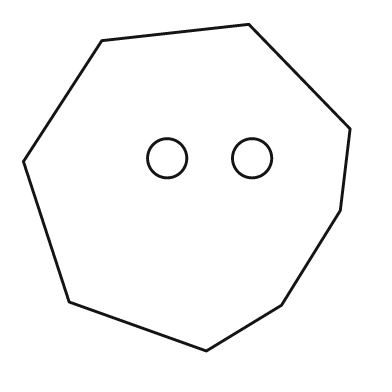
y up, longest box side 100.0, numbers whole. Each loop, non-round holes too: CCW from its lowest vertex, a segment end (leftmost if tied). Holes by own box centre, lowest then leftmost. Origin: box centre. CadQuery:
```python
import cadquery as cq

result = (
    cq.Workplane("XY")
    .moveTo(6.0, -50.0)
    .lineTo(29.0, -36.0)
    .lineTo(47.0, -7.0)
    .lineTo(50.0, 18.0)
    .lineTo(19.0, 50.0)
    .lineTo(-26.0, 45.0)
    .lineTo(-50.0, 8.0)
    .lineTo(-36.0, -35.0)
    .close()
    .moveTo(-6.0, 9.0)
    .circle(6.0)
    .moveTo(20.0, 9.0)
    .circle(6.0)
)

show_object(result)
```